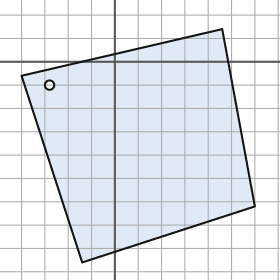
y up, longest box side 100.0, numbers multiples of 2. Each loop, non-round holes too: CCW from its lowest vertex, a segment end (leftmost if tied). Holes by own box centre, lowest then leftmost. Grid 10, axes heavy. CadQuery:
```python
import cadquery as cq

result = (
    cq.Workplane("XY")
    .moveTo(-14.0, -86.0)
    .lineTo(60.0, -62.0)
    .lineTo(46.0, 14.0)
    .lineTo(-40.0, -6.0)
    .close()
    .moveTo(-28.0, -10.0)
    .circle(2.0)
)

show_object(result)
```